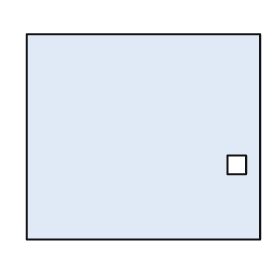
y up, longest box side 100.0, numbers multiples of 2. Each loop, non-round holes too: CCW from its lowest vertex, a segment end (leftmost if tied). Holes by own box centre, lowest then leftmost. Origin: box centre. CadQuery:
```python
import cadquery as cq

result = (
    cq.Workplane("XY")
    .moveTo(-50.0, -44.0)
    .lineTo(50.0, -44.0)
    .lineTo(50.0, 44.0)
    .lineTo(-50.0, 44.0)
    .close()
    .moveTo(36.0, -16.0)
    .lineTo(44.0, -16.0)
    .lineTo(44.0, -8.0)
    .lineTo(36.0, -8.0)
    .close()
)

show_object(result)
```